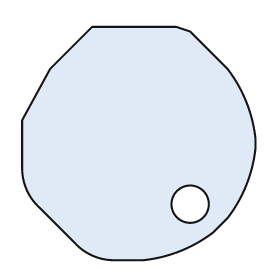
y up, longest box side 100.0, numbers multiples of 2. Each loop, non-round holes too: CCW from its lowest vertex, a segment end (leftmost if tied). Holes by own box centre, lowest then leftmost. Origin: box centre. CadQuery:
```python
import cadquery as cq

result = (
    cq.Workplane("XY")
    .moveTo(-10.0, -50.0)
    .lineTo(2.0, -50.0)
    .threePointArc((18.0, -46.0), (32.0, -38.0))
    .lineTo(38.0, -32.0)
    .threePointArc((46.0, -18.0), (50.0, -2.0))
    .lineTo(50.0, 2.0)
    .threePointArc((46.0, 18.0), (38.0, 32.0))
    .lineTo(22.0, 48.0)
    .lineTo(16.0, 50.0)
    .lineTo(-20.0, 50.0)
    .lineTo(-38.0, 32.0)
    .lineTo(-50.0, 10.0)
    .lineTo(-50.0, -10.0)
    .threePointArc((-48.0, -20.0), (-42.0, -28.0))
    .lineTo(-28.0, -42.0)
    .threePointArc((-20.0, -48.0), (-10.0, -50.0))
    .close()
    .moveTo(22.0, -26.0)
    .circle(8.0)
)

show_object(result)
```